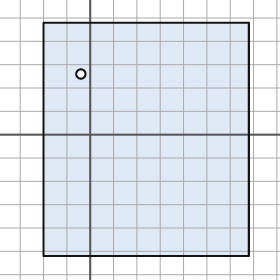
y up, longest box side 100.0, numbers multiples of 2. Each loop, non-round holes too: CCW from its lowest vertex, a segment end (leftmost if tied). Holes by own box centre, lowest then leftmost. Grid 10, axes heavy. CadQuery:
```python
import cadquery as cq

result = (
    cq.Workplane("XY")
    .moveTo(-20.0, -52.0)
    .lineTo(68.0, -52.0)
    .lineTo(68.0, 48.0)
    .lineTo(-20.0, 48.0)
    .close()
    .moveTo(-4.0, 26.0)
    .circle(2.0)
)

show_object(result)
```